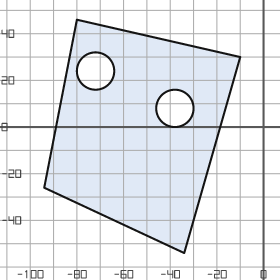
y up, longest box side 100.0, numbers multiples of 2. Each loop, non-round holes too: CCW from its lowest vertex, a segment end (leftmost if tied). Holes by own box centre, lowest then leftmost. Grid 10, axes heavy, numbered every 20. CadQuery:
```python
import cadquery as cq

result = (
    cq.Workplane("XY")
    .moveTo(-34.0, -54.0)
    .lineTo(-10.0, 30.0)
    .lineTo(-80.0, 46.0)
    .lineTo(-94.0, -26.0)
    .close()
    .moveTo(-38.0, 8.0)
    .circle(8.0)
    .moveTo(-72.0, 24.0)
    .circle(8.0)
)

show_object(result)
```